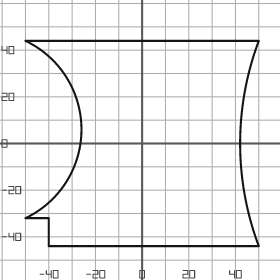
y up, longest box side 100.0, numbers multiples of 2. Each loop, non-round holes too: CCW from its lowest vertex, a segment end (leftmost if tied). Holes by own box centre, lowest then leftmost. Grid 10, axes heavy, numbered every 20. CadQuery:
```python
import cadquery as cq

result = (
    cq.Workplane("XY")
    .moveTo(-40.0, -44.0)
    .lineTo(50.0, -44.0)
    .threePointArc((42.0, 0.0), (50.0, 44.0))
    .lineTo(-50.0, 44.0)
    .threePointArc((-26.0, 6.0), (-50.0, -32.0))
    .lineTo(-40.0, -32.0)
    .close()
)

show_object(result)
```